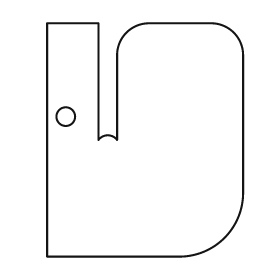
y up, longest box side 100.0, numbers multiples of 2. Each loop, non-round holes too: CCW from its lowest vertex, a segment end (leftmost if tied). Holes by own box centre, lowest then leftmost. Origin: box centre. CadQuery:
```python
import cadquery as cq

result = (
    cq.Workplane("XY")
    .moveTo(-42.0, -50.0)
    .lineTo(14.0, -50.0)
    .threePointArc((34.0, -42.0), (42.0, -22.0))
    .lineTo(42.0, 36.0)
    .threePointArc((38.0, 46.0), (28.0, 50.0))
    .lineTo(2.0, 50.0)
    .threePointArc((-8.0, 46.0), (-12.0, 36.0))
    .lineTo(-12.0, 0.0)
    .threePointArc((-16.0, 2.0), (-20.0, 0.0))
    .lineTo(-20.0, 50.0)
    .lineTo(-42.0, 50.0)
    .close()
    .moveTo(-34.0, 10.0)
    .circle(4.0)
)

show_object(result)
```